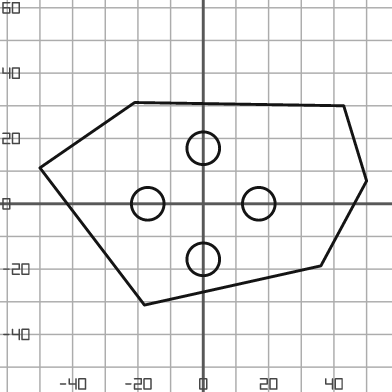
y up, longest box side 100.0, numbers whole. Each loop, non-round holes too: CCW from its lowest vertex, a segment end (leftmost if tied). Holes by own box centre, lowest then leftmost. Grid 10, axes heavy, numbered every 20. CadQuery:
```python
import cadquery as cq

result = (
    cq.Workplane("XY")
    .moveTo(-18.0, -31.0)
    .lineTo(36.0, -19.0)
    .lineTo(50.0, 7.0)
    .lineTo(43.0, 30.0)
    .lineTo(-21.0, 31.0)
    .lineTo(-50.0, 11.0)
    .close()
    .moveTo(0.0, -17.0)
    .circle(5.0)
    .moveTo(-17.0, 0.0)
    .circle(5.0)
    .moveTo(17.0, 0.0)
    .circle(5.0)
    .moveTo(0.0, 17.0)
    .circle(5.0)
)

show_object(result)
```